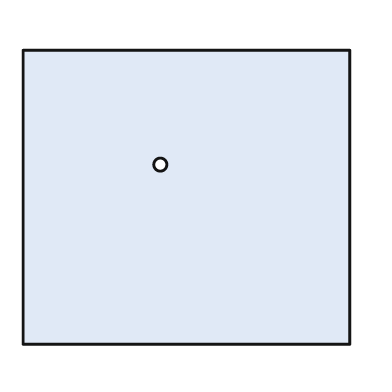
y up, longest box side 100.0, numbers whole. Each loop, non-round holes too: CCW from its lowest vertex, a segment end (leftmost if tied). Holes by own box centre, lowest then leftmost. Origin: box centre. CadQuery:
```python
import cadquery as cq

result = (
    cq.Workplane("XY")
    .moveTo(-50.0, -45.0)
    .lineTo(50.0, -45.0)
    .lineTo(50.0, 45.0)
    .lineTo(-50.0, 45.0)
    .close()
    .moveTo(-8.0, 10.0)
    .circle(2.0)
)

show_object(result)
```